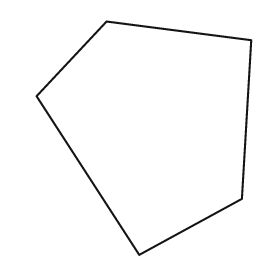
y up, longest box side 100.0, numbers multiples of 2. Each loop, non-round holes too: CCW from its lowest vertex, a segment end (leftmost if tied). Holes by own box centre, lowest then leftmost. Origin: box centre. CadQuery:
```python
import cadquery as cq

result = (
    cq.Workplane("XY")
    .moveTo(-2.0, -50.0)
    .lineTo(42.0, -26.0)
    .lineTo(46.0, 42.0)
    .lineTo(-16.0, 50.0)
    .lineTo(-46.0, 18.0)
    .close()
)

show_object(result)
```